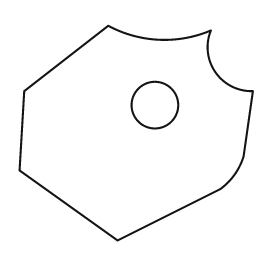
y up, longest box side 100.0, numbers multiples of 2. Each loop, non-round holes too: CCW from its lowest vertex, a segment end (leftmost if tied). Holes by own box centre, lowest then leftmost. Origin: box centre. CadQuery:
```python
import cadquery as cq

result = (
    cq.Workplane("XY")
    .moveTo(-8.0, -46.0)
    .lineTo(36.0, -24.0)
    .threePointArc((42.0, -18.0), (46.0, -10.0))
    .lineTo(50.0, 18.0)
    .threePointArc((34.0, 26.0), (32.0, 44.0))
    .threePointArc((10.0, 40.0), (-12.0, 46.0))
    .lineTo(-48.0, 18.0)
    .lineTo(-50.0, -16.0)
    .close()
    .moveTo(8.0, 12.0)
    .circle(10.0)
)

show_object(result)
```